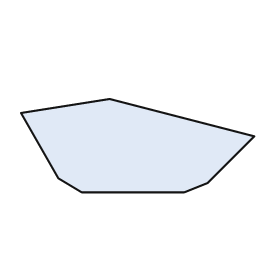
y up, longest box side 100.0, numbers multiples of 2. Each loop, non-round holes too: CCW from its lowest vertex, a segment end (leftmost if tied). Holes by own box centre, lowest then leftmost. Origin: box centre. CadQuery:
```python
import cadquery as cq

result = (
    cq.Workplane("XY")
    .moveTo(-24.0, -20.0)
    .lineTo(20.0, -20.0)
    .lineTo(30.0, -16.0)
    .lineTo(50.0, 4.0)
    .lineTo(-12.0, 20.0)
    .lineTo(-50.0, 14.0)
    .lineTo(-34.0, -14.0)
    .close()
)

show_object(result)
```